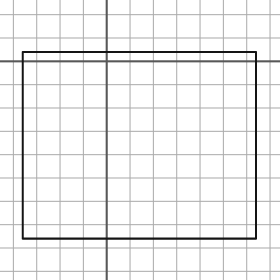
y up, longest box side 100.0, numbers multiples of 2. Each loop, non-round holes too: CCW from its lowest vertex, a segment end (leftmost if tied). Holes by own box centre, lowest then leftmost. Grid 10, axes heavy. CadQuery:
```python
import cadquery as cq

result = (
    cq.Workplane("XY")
    .moveTo(-36.0, -76.0)
    .lineTo(64.0, -76.0)
    .lineTo(64.0, 4.0)
    .lineTo(-36.0, 4.0)
    .close()
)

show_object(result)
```